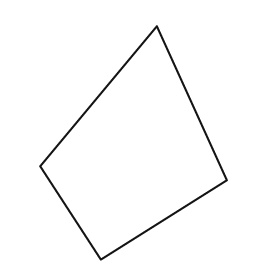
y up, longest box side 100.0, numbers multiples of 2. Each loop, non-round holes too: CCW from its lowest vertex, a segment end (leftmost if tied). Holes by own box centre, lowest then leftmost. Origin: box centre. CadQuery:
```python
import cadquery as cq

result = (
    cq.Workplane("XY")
    .moveTo(-14.0, -50.0)
    .lineTo(40.0, -16.0)
    .lineTo(10.0, 50.0)
    .lineTo(-40.0, -10.0)
    .close()
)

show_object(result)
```